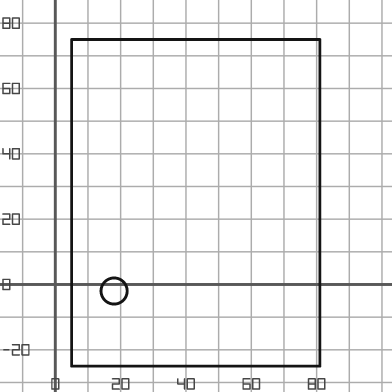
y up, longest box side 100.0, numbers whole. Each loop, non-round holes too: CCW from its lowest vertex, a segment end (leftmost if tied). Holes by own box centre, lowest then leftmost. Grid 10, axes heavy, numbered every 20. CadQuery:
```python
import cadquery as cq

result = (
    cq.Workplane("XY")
    .moveTo(5.0, -25.0)
    .lineTo(81.0, -25.0)
    .lineTo(81.0, 75.0)
    .lineTo(5.0, 75.0)
    .close()
    .moveTo(18.0, -2.0)
    .circle(4.0)
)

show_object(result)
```